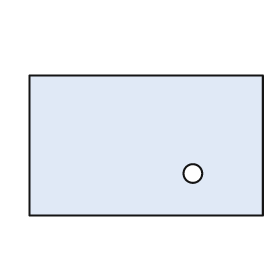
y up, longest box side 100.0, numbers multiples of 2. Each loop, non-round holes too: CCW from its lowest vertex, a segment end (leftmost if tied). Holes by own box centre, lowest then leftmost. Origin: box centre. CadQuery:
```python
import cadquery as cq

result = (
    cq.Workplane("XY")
    .moveTo(-50.0, -30.0)
    .lineTo(50.0, -30.0)
    .lineTo(50.0, 30.0)
    .lineTo(-50.0, 30.0)
    .close()
    .moveTo(20.0, -12.0)
    .circle(4.0)
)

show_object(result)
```